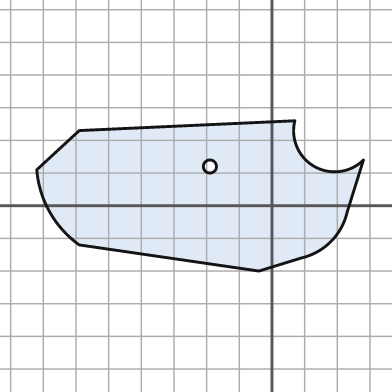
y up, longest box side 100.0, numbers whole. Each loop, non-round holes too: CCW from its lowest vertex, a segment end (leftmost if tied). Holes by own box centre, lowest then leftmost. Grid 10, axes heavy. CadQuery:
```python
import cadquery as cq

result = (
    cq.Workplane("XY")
    .moveTo(-4.0, -20.0)
    .lineTo(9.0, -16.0)
    .threePointArc((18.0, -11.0), (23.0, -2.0))
    .lineTo(28.0, 14.0)
    .threePointArc((13.0, 12.0), (7.0, 26.0))
    .lineTo(-59.0, 23.0)
    .lineTo(-72.0, 11.0)
    .threePointArc((-68.0, -2.0), (-59.0, -12.0))
    .close()
    .moveTo(-19.0, 12.0)
    .circle(2.0)
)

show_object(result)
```